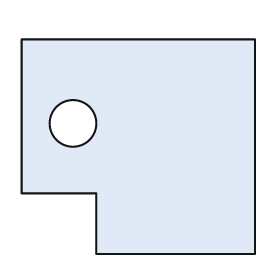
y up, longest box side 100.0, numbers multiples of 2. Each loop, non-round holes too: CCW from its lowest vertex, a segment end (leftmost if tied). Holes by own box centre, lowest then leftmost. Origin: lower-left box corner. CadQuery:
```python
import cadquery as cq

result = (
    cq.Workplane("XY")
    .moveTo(32.0, 0.0)
    .lineTo(100.0, 0.0)
    .lineTo(100.0, 92.0)
    .lineTo(0.0, 92.0)
    .lineTo(0.0, 26.0)
    .lineTo(32.0, 26.0)
    .close()
    .moveTo(22.0, 56.0)
    .circle(10.0)
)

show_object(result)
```